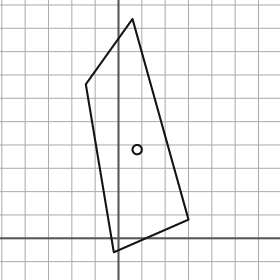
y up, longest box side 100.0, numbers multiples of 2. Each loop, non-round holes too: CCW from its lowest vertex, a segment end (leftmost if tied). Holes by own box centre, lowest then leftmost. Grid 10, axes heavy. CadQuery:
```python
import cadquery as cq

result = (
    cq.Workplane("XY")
    .moveTo(-2.0, -6.0)
    .lineTo(30.0, 8.0)
    .lineTo(6.0, 94.0)
    .lineTo(-14.0, 66.0)
    .close()
    .moveTo(8.0, 38.0)
    .circle(2.0)
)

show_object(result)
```